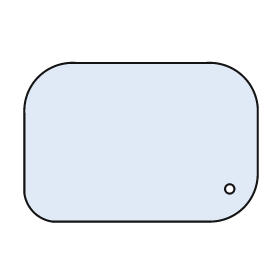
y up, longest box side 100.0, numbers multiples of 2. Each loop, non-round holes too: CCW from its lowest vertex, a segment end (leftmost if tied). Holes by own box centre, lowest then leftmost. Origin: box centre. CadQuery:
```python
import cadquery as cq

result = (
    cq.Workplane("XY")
    .moveTo(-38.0, -34.0)
    .lineTo(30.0, -34.0)
    .threePointArc((44.0, -28.0), (50.0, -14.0))
    .lineTo(50.0, 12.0)
    .threePointArc((44.0, 28.0), (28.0, 34.0))
    .lineTo(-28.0, 34.0)
    .threePointArc((-44.0, 28.0), (-50.0, 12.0))
    .lineTo(-50.0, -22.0)
    .threePointArc((-46.0, -30.0), (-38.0, -34.0))
    .close()
    .moveTo(38.0, -20.0)
    .circle(2.0)
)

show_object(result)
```